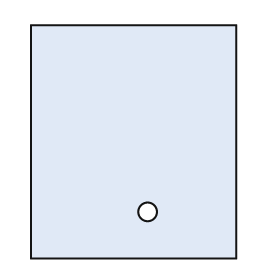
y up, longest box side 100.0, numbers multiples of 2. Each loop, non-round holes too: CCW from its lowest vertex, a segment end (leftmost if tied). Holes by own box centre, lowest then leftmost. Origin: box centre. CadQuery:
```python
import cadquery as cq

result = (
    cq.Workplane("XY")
    .moveTo(-44.0, -50.0)
    .lineTo(44.0, -50.0)
    .lineTo(44.0, 50.0)
    .lineTo(-44.0, 50.0)
    .close()
    .moveTo(6.0, -30.0)
    .circle(4.0)
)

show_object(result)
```